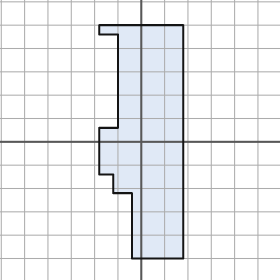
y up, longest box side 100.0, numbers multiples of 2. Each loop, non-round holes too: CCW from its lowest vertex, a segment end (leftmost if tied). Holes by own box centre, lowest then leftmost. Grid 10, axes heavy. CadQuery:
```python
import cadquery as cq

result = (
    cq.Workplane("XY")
    .moveTo(-4.0, -50.0)
    .lineTo(18.0, -50.0)
    .lineTo(18.0, 50.0)
    .lineTo(-18.0, 50.0)
    .lineTo(-18.0, 46.0)
    .lineTo(-10.0, 46.0)
    .lineTo(-10.0, 6.0)
    .lineTo(-18.0, 6.0)
    .lineTo(-18.0, -14.0)
    .lineTo(-12.0, -14.0)
    .lineTo(-12.0, -22.0)
    .lineTo(-4.0, -22.0)
    .close()
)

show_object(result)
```